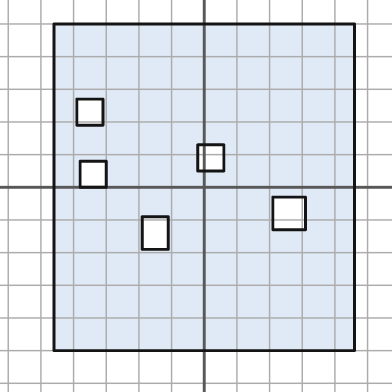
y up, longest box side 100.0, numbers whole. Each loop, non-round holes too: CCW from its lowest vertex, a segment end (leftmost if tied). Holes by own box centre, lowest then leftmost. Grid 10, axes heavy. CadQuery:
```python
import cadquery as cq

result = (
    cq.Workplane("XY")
    .moveTo(-46.0, -50.0)
    .lineTo(46.0, -50.0)
    .lineTo(46.0, 50.0)
    .lineTo(-46.0, 50.0)
    .close()
    .moveTo(-19.0, -19.0)
    .lineTo(-11.0, -19.0)
    .lineTo(-11.0, -9.0)
    .lineTo(-19.0, -9.0)
    .close()
    .moveTo(21.0, -13.0)
    .lineTo(31.0, -13.0)
    .lineTo(31.0, -3.0)
    .lineTo(21.0, -3.0)
    .close()
    .moveTo(-38.0, 0.0)
    .lineTo(-30.0, 0.0)
    .lineTo(-30.0, 8.0)
    .lineTo(-38.0, 8.0)
    .close()
    .moveTo(-2.0, 5.0)
    .lineTo(6.0, 5.0)
    .lineTo(6.0, 13.0)
    .lineTo(-2.0, 13.0)
    .close()
    .moveTo(-39.0, 19.0)
    .lineTo(-31.0, 19.0)
    .lineTo(-31.0, 27.0)
    .lineTo(-39.0, 27.0)
    .close()
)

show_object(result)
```